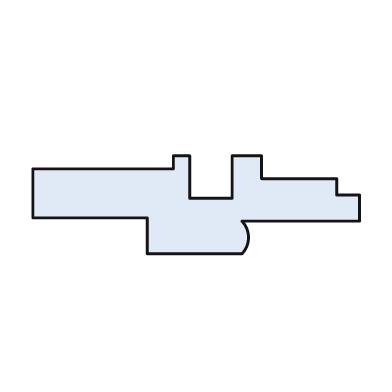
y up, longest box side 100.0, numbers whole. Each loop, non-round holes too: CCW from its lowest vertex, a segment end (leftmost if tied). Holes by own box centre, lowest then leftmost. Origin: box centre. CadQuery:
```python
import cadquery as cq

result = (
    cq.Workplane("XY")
    .moveTo(-15.0, -15.0)
    .lineTo(14.0, -15.0)
    .threePointArc((16.0, -10.0), (14.0, -5.0))
    .lineTo(50.0, -5.0)
    .lineTo(50.0, 3.0)
    .lineTo(43.0, 3.0)
    .lineTo(43.0, 8.0)
    .lineTo(20.0, 8.0)
    .lineTo(20.0, 15.0)
    .lineTo(11.0, 15.0)
    .lineTo(11.0, 2.0)
    .lineTo(-2.0, 2.0)
    .lineTo(-2.0, 15.0)
    .lineTo(-7.0, 15.0)
    .lineTo(-7.0, 11.0)
    .lineTo(-50.0, 11.0)
    .lineTo(-50.0, -4.0)
    .lineTo(-15.0, -4.0)
    .close()
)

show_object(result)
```